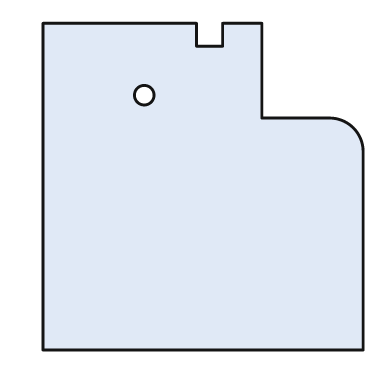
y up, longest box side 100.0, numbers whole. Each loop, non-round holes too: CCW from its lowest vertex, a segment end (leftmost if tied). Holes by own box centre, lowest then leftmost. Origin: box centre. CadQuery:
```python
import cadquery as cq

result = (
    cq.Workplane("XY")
    .moveTo(-49.0, -50.0)
    .lineTo(49.0, -50.0)
    .lineTo(49.0, 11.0)
    .threePointArc((46.0, 18.0), (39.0, 21.0))
    .lineTo(18.0, 21.0)
    .lineTo(18.0, 50.0)
    .lineTo(6.0, 50.0)
    .lineTo(6.0, 43.0)
    .lineTo(-2.0, 43.0)
    .lineTo(-2.0, 50.0)
    .lineTo(-49.0, 50.0)
    .close()
    .moveTo(-18.0, 28.0)
    .circle(3.0)
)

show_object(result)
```